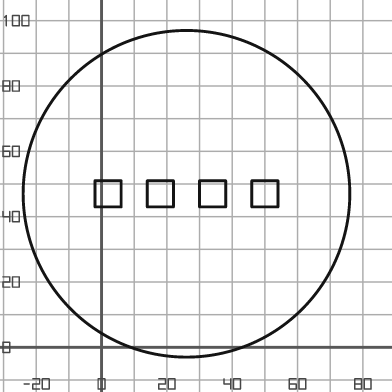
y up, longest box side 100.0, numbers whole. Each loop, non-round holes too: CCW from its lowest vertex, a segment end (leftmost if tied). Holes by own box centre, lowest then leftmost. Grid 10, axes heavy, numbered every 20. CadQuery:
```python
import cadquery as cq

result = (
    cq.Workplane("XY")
    .moveTo(26.0, 47.0)
    .circle(50.0)
    .moveTo(-2.0, 43.0)
    .lineTo(6.0, 43.0)
    .lineTo(6.0, 51.0)
    .lineTo(-2.0, 51.0)
    .close()
    .moveTo(14.0, 43.0)
    .lineTo(22.0, 43.0)
    .lineTo(22.0, 51.0)
    .lineTo(14.0, 51.0)
    .close()
    .moveTo(30.0, 43.0)
    .lineTo(38.0, 43.0)
    .lineTo(38.0, 51.0)
    .lineTo(30.0, 51.0)
    .close()
    .moveTo(46.0, 43.0)
    .lineTo(54.0, 43.0)
    .lineTo(54.0, 51.0)
    .lineTo(46.0, 51.0)
    .close()
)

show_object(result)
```